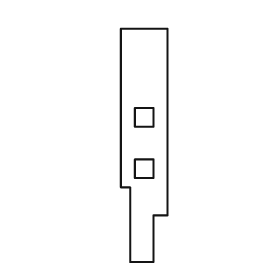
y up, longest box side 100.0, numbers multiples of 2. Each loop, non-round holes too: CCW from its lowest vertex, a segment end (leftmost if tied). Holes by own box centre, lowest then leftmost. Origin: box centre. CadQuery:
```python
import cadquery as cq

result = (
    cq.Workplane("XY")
    .moveTo(-6.0, -50.0)
    .lineTo(4.0, -50.0)
    .lineTo(4.0, -30.0)
    .lineTo(10.0, -30.0)
    .lineTo(10.0, 50.0)
    .lineTo(-10.0, 50.0)
    .lineTo(-10.0, -18.0)
    .lineTo(-6.0, -18.0)
    .close()
    .moveTo(-4.0, -14.0)
    .lineTo(4.0, -14.0)
    .lineTo(4.0, -6.0)
    .lineTo(-4.0, -6.0)
    .close()
    .moveTo(-4.0, 8.0)
    .lineTo(4.0, 8.0)
    .lineTo(4.0, 16.0)
    .lineTo(-4.0, 16.0)
    .close()
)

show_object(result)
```